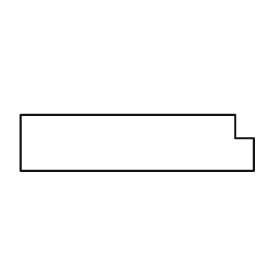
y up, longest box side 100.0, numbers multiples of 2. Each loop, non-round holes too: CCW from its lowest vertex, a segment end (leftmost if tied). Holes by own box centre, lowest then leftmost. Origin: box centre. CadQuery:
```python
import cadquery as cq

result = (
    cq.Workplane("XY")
    .moveTo(-50.0, -12.0)
    .lineTo(50.0, -12.0)
    .lineTo(50.0, 2.0)
    .lineTo(42.0, 2.0)
    .lineTo(42.0, 12.0)
    .lineTo(-50.0, 12.0)
    .close()
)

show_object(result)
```